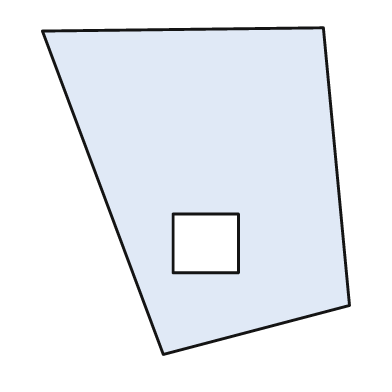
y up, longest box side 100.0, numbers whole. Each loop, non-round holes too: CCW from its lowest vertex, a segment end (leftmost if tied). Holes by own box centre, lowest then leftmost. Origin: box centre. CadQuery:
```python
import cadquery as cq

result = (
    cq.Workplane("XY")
    .moveTo(-10.0, -50.0)
    .lineTo(47.0, -35.0)
    .lineTo(39.0, 50.0)
    .lineTo(-47.0, 49.0)
    .close()
    .moveTo(-7.0, -25.0)
    .lineTo(13.0, -25.0)
    .lineTo(13.0, -7.0)
    .lineTo(-7.0, -7.0)
    .close()
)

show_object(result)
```